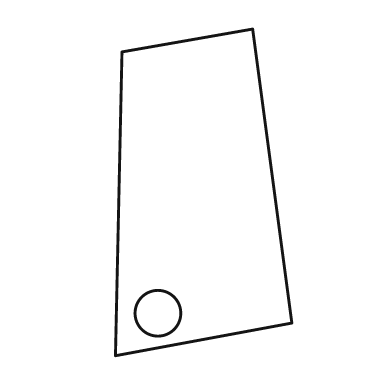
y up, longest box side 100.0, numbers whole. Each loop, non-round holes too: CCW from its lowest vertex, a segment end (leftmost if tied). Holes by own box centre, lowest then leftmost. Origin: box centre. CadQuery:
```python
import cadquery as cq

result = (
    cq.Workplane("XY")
    .moveTo(-27.0, -50.0)
    .lineTo(27.0, -40.0)
    .lineTo(15.0, 50.0)
    .lineTo(-25.0, 43.0)
    .close()
    .moveTo(-14.0, -37.0)
    .circle(7.0)
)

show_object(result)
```